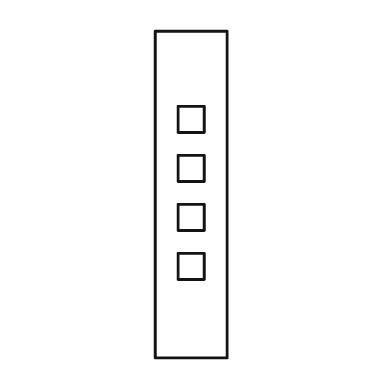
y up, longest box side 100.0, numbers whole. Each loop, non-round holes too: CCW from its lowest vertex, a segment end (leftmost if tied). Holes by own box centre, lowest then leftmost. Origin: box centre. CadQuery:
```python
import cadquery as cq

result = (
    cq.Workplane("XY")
    .moveTo(-11.0, -50.0)
    .lineTo(11.0, -50.0)
    .lineTo(11.0, 50.0)
    .lineTo(-11.0, 50.0)
    .close()
    .moveTo(-4.0, -26.0)
    .lineTo(4.0, -26.0)
    .lineTo(4.0, -18.0)
    .lineTo(-4.0, -18.0)
    .close()
    .moveTo(-4.0, -11.0)
    .lineTo(4.0, -11.0)
    .lineTo(4.0, -3.0)
    .lineTo(-4.0, -3.0)
    .close()
    .moveTo(-4.0, 4.0)
    .lineTo(4.0, 4.0)
    .lineTo(4.0, 12.0)
    .lineTo(-4.0, 12.0)
    .close()
    .moveTo(-4.0, 19.0)
    .lineTo(4.0, 19.0)
    .lineTo(4.0, 27.0)
    .lineTo(-4.0, 27.0)
    .close()
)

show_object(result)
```